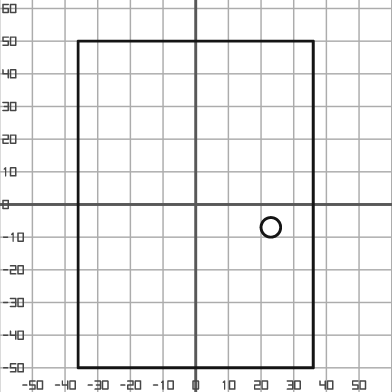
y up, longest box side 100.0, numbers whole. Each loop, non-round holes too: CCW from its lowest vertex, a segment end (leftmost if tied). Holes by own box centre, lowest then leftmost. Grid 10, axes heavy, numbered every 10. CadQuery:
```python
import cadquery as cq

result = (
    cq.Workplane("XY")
    .moveTo(-36.0, -50.0)
    .lineTo(36.0, -50.0)
    .lineTo(36.0, 50.0)
    .lineTo(-36.0, 50.0)
    .close()
    .moveTo(23.0, -7.0)
    .circle(3.0)
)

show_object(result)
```